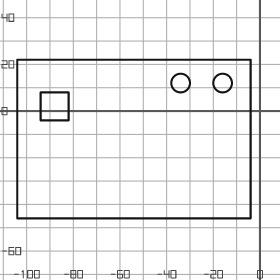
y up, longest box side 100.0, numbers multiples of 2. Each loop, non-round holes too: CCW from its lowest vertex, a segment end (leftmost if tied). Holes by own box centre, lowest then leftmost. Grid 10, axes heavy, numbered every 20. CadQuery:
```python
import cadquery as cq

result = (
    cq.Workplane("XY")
    .moveTo(-104.0, -46.0)
    .lineTo(-4.0, -46.0)
    .lineTo(-4.0, 22.0)
    .lineTo(-104.0, 22.0)
    .close()
    .moveTo(-94.0, -4.0)
    .lineTo(-82.0, -4.0)
    .lineTo(-82.0, 8.0)
    .lineTo(-94.0, 8.0)
    .close()
    .moveTo(-34.0, 12.0)
    .circle(4.0)
    .moveTo(-16.0, 12.0)
    .circle(4.0)
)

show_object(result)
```